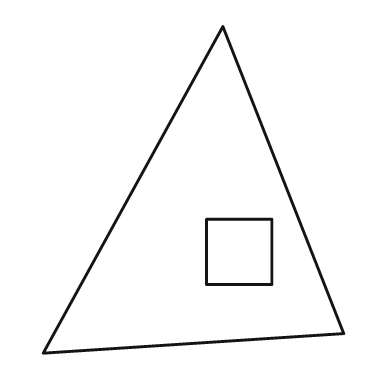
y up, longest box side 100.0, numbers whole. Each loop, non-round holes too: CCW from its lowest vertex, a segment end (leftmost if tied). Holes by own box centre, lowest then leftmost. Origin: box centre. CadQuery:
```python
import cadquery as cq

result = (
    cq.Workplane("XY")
    .moveTo(-46.0, -50.0)
    .lineTo(46.0, -44.0)
    .lineTo(9.0, 50.0)
    .close()
    .moveTo(4.0, -29.0)
    .lineTo(24.0, -29.0)
    .lineTo(24.0, -9.0)
    .lineTo(4.0, -9.0)
    .close()
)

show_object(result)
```